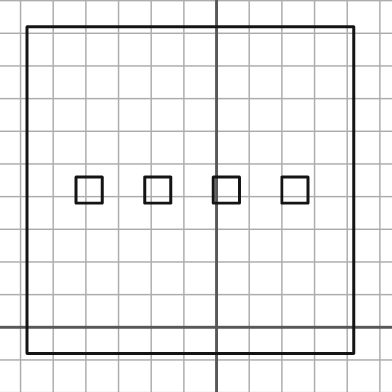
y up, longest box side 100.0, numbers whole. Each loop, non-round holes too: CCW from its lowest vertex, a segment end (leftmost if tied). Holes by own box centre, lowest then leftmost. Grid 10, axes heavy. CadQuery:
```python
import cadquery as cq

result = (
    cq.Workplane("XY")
    .moveTo(-58.0, -8.0)
    .lineTo(42.0, -8.0)
    .lineTo(42.0, 92.0)
    .lineTo(-58.0, 92.0)
    .close()
    .moveTo(-43.0, 38.0)
    .lineTo(-35.0, 38.0)
    .lineTo(-35.0, 46.0)
    .lineTo(-43.0, 46.0)
    .close()
    .moveTo(-22.0, 38.0)
    .lineTo(-14.0, 38.0)
    .lineTo(-14.0, 46.0)
    .lineTo(-22.0, 46.0)
    .close()
    .moveTo(-1.0, 38.0)
    .lineTo(7.0, 38.0)
    .lineTo(7.0, 46.0)
    .lineTo(-1.0, 46.0)
    .close()
    .moveTo(20.0, 38.0)
    .lineTo(28.0, 38.0)
    .lineTo(28.0, 46.0)
    .lineTo(20.0, 46.0)
    .close()
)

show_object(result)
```